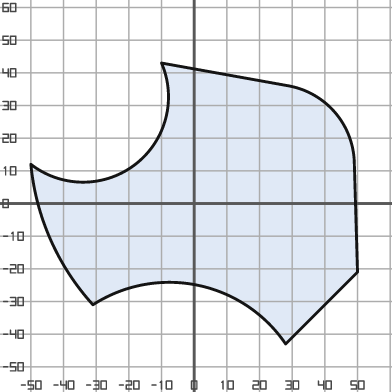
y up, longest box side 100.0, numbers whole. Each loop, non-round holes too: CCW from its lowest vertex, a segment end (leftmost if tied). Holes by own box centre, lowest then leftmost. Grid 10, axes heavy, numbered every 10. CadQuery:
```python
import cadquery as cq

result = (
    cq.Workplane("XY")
    .moveTo(28.0, -43.0)
    .lineTo(50.0, -21.0)
    .lineTo(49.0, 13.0)
    .threePointArc((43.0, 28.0), (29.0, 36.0))
    .lineTo(-10.0, 43.0)
    .threePointArc((-18.0, 12.0), (-50.0, 12.0))
    .threePointArc((-44.0, -11.0), (-31.0, -31.0))
    .threePointArc((1.0, -25.0), (28.0, -43.0))
    .close()
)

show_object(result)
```